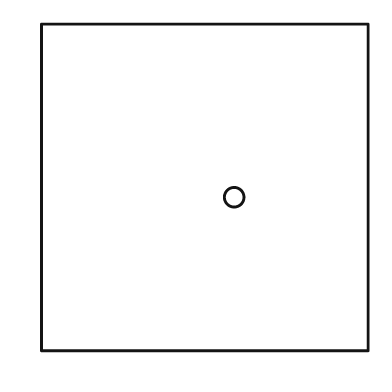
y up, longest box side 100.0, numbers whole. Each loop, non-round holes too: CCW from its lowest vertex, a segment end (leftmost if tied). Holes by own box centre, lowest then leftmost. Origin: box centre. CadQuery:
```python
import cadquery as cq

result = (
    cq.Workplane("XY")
    .moveTo(-50.0, -50.0)
    .lineTo(50.0, -50.0)
    .lineTo(50.0, 50.0)
    .lineTo(-50.0, 50.0)
    .close()
    .moveTo(9.0, -3.0)
    .circle(3.0)
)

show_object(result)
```